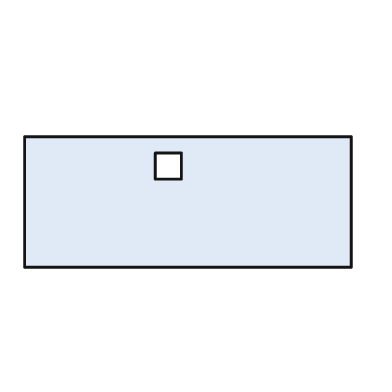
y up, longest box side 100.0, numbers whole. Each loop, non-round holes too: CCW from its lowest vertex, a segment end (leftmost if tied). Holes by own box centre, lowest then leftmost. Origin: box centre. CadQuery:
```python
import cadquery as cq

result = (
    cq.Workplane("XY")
    .moveTo(-50.0, -20.0)
    .lineTo(50.0, -20.0)
    .lineTo(50.0, 20.0)
    .lineTo(-50.0, 20.0)
    .close()
    .moveTo(-10.0, 7.0)
    .lineTo(-2.0, 7.0)
    .lineTo(-2.0, 15.0)
    .lineTo(-10.0, 15.0)
    .close()
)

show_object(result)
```